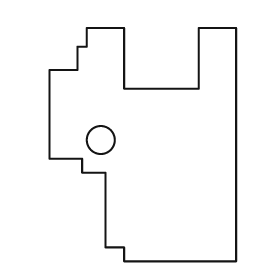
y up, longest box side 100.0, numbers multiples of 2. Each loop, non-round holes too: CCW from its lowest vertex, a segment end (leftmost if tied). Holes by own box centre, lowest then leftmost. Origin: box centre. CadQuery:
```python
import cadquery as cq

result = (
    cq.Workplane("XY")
    .moveTo(-8.0, -50.0)
    .lineTo(40.0, -50.0)
    .lineTo(40.0, 50.0)
    .lineTo(24.0, 50.0)
    .lineTo(24.0, 24.0)
    .lineTo(-8.0, 24.0)
    .lineTo(-8.0, 50.0)
    .lineTo(-24.0, 50.0)
    .lineTo(-24.0, 42.0)
    .lineTo(-28.0, 42.0)
    .lineTo(-28.0, 32.0)
    .lineTo(-40.0, 32.0)
    .lineTo(-40.0, -6.0)
    .lineTo(-26.0, -6.0)
    .lineTo(-26.0, -12.0)
    .lineTo(-16.0, -12.0)
    .lineTo(-16.0, -44.0)
    .lineTo(-8.0, -44.0)
    .close()
    .moveTo(-18.0, 2.0)
    .circle(6.0)
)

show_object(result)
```